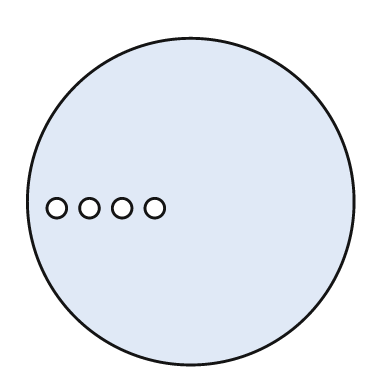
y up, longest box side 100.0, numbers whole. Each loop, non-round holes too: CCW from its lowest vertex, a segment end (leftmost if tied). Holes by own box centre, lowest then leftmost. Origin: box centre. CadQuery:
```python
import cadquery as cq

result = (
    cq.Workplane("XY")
    .moveTo(0.0, 0.0)
    .circle(50.0)
    .moveTo(-41.0, -2.0)
    .circle(3.0)
    .moveTo(-31.0, -2.0)
    .circle(3.0)
    .moveTo(-21.0, -2.0)
    .circle(3.0)
    .moveTo(-11.0, -2.0)
    .circle(3.0)
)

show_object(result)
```